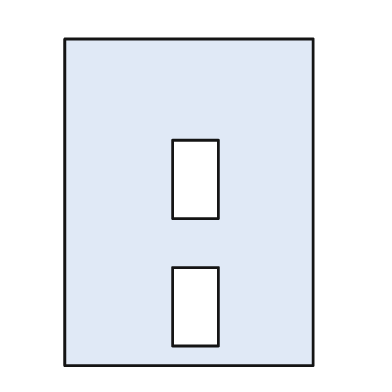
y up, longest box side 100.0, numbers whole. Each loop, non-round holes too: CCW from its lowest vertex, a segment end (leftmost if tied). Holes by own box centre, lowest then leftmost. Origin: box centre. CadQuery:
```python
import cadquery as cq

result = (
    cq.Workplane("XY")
    .moveTo(-38.0, -50.0)
    .lineTo(38.0, -50.0)
    .lineTo(38.0, 50.0)
    .lineTo(-38.0, 50.0)
    .close()
    .moveTo(-5.0, -44.0)
    .lineTo(9.0, -44.0)
    .lineTo(9.0, -20.0)
    .lineTo(-5.0, -20.0)
    .close()
    .moveTo(-5.0, -5.0)
    .lineTo(9.0, -5.0)
    .lineTo(9.0, 19.0)
    .lineTo(-5.0, 19.0)
    .close()
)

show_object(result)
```